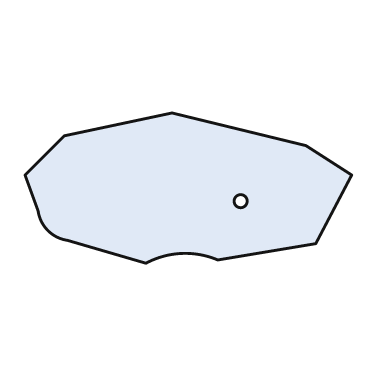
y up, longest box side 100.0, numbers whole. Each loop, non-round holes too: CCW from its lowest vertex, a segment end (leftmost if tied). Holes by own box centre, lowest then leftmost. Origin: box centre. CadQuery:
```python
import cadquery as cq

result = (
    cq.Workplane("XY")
    .moveTo(-13.0, -23.0)
    .threePointArc((-2.0, -20.0), (9.0, -22.0))
    .lineTo(39.0, -17.0)
    .lineTo(50.0, 4.0)
    .lineTo(36.0, 13.0)
    .lineTo(-5.0, 23.0)
    .lineTo(-38.0, 16.0)
    .lineTo(-50.0, 4.0)
    .lineTo(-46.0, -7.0)
    .threePointArc((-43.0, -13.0), (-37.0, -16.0))
    .close()
    .moveTo(16.0, -4.0)
    .circle(2.0)
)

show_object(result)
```